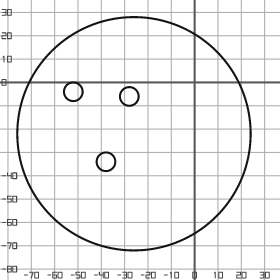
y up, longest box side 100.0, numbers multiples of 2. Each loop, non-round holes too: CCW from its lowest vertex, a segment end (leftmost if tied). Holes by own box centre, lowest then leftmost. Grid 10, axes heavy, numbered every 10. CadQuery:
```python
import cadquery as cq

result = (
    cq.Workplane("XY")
    .moveTo(-26.0, -22.0)
    .circle(50.0)
    .moveTo(-38.0, -34.0)
    .circle(4.0)
    .moveTo(-28.0, -6.0)
    .circle(4.0)
    .moveTo(-52.0, -4.0)
    .circle(4.0)
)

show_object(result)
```